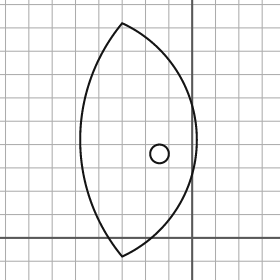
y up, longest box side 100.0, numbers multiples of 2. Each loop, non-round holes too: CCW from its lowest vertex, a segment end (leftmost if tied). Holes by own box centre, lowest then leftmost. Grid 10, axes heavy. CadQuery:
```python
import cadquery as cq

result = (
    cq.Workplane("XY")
    .moveTo(-30.0, -8.0)
    .threePointArc((2.0, 42.0), (-30.0, 92.0))
    .threePointArc((-48.0, 42.0), (-30.0, -8.0))
    .close()
    .moveTo(-14.0, 36.0)
    .circle(4.0)
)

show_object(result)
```